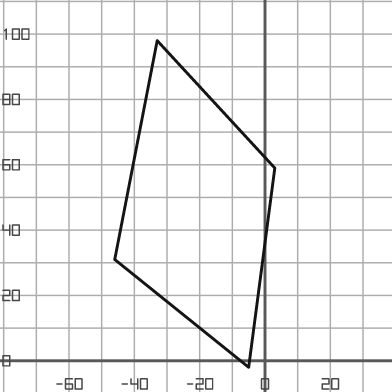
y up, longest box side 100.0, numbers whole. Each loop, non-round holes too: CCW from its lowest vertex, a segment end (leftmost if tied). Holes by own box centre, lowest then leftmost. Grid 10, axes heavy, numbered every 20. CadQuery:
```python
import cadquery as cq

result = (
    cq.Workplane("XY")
    .moveTo(-5.0, -2.0)
    .lineTo(3.0, 59.0)
    .lineTo(-33.0, 98.0)
    .lineTo(-46.0, 31.0)
    .close()
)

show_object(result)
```